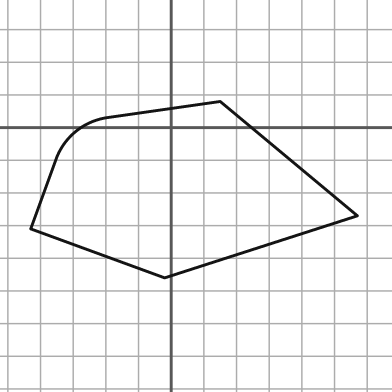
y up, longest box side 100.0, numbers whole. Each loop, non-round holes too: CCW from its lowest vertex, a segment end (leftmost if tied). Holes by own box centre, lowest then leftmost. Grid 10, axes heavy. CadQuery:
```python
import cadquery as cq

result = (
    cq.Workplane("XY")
    .moveTo(-2.0, -46.0)
    .lineTo(57.0, -27.0)
    .lineTo(15.0, 8.0)
    .lineTo(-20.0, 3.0)
    .threePointArc((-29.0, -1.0), (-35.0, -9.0))
    .lineTo(-43.0, -31.0)
    .close()
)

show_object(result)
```